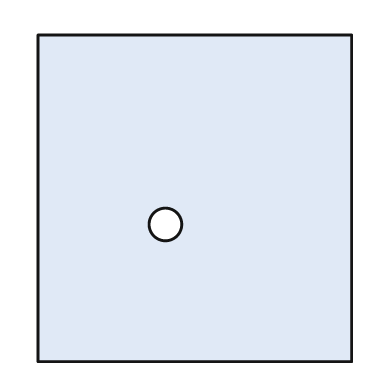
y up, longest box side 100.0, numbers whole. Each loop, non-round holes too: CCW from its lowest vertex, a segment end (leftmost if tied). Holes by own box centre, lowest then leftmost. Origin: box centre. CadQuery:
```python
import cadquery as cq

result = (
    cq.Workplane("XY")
    .moveTo(-48.0, -50.0)
    .lineTo(48.0, -50.0)
    .lineTo(48.0, 50.0)
    .lineTo(-48.0, 50.0)
    .close()
    .moveTo(-9.0, -8.0)
    .circle(5.0)
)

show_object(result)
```